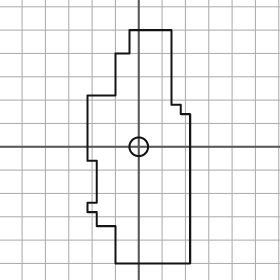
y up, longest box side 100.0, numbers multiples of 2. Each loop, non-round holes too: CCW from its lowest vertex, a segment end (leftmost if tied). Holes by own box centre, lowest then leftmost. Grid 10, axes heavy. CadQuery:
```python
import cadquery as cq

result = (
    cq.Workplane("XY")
    .moveTo(-10.0, -50.0)
    .lineTo(22.0, -50.0)
    .lineTo(22.0, 14.0)
    .lineTo(18.0, 14.0)
    .lineTo(18.0, 18.0)
    .lineTo(14.0, 18.0)
    .lineTo(14.0, 50.0)
    .lineTo(-4.0, 50.0)
    .lineTo(-4.0, 40.0)
    .lineTo(-10.0, 40.0)
    .lineTo(-10.0, 22.0)
    .lineTo(-22.0, 22.0)
    .lineTo(-22.0, -6.0)
    .lineTo(-18.0, -6.0)
    .lineTo(-18.0, -24.0)
    .lineTo(-22.0, -24.0)
    .lineTo(-22.0, -28.0)
    .lineTo(-18.0, -28.0)
    .lineTo(-18.0, -34.0)
    .lineTo(-10.0, -34.0)
    .close()
    .moveTo(0.0, 0.0)
    .circle(4.0)
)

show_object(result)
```